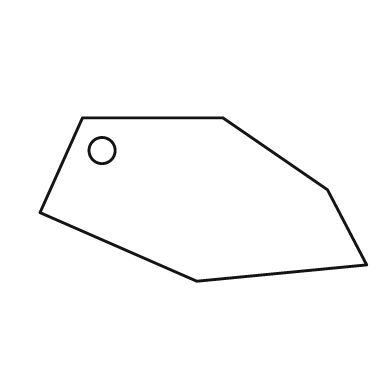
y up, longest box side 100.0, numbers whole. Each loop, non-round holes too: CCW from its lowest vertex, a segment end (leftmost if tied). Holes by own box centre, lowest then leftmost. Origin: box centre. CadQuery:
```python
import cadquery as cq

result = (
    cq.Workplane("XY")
    .moveTo(-2.0, -25.0)
    .lineTo(50.0, -20.0)
    .lineTo(38.0, 3.0)
    .lineTo(6.0, 25.0)
    .lineTo(-37.0, 25.0)
    .lineTo(-50.0, -4.0)
    .close()
    .moveTo(-31.0, 15.0)
    .circle(4.0)
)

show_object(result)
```